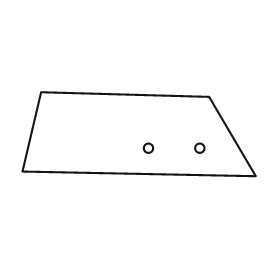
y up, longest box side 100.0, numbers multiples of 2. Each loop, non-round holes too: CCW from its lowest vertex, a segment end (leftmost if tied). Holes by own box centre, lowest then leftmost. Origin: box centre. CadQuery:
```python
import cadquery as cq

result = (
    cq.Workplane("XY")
    .moveTo(50.0, -18.0)
    .lineTo(30.0, 16.0)
    .lineTo(-42.0, 18.0)
    .lineTo(-50.0, -16.0)
    .close()
    .moveTo(4.0, -6.0)
    .circle(2.0)
    .moveTo(26.0, -6.0)
    .circle(2.0)
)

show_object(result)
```